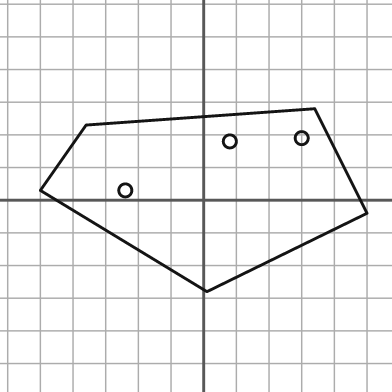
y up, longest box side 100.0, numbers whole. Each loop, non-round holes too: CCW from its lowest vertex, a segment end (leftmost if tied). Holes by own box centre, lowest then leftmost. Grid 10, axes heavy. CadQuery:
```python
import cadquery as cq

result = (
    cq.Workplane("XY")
    .moveTo(1.0, -28.0)
    .lineTo(50.0, -4.0)
    .lineTo(34.0, 28.0)
    .lineTo(-36.0, 23.0)
    .lineTo(-50.0, 3.0)
    .close()
    .moveTo(-24.0, 3.0)
    .circle(2.0)
    .moveTo(8.0, 18.0)
    .circle(2.0)
    .moveTo(30.0, 19.0)
    .circle(2.0)
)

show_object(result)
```